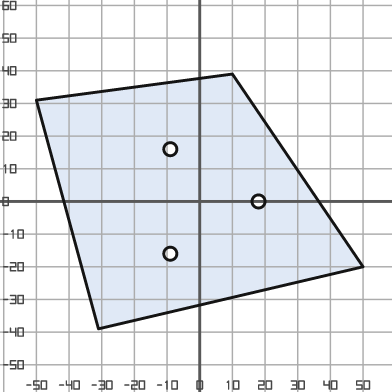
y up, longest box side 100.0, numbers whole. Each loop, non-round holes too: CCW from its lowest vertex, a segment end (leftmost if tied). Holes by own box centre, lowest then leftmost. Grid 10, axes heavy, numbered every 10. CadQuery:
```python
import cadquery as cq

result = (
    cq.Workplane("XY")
    .moveTo(-31.0, -39.0)
    .lineTo(50.0, -20.0)
    .lineTo(10.0, 39.0)
    .lineTo(-50.0, 31.0)
    .close()
    .moveTo(-9.0, -16.0)
    .circle(2.0)
    .moveTo(18.0, 0.0)
    .circle(2.0)
    .moveTo(-9.0, 16.0)
    .circle(2.0)
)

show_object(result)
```